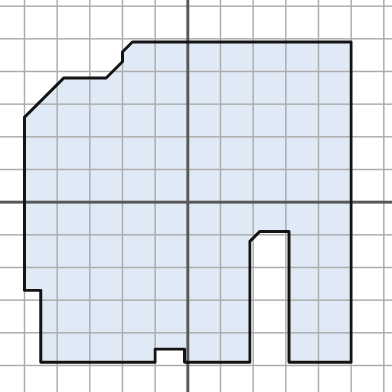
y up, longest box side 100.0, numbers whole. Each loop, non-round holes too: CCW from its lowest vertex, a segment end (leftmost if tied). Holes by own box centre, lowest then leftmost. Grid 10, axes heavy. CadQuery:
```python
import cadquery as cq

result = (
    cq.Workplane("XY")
    .moveTo(-45.0, -49.0)
    .lineTo(-10.0, -49.0)
    .lineTo(-10.0, -45.0)
    .lineTo(-1.0, -45.0)
    .lineTo(-1.0, -49.0)
    .lineTo(19.0, -49.0)
    .lineTo(19.0, -12.0)
    .lineTo(22.0, -9.0)
    .lineTo(31.0, -9.0)
    .lineTo(31.0, -49.0)
    .lineTo(50.0, -49.0)
    .lineTo(50.0, 49.0)
    .lineTo(-17.0, 49.0)
    .lineTo(-20.0, 46.0)
    .lineTo(-20.0, 43.0)
    .lineTo(-25.0, 38.0)
    .lineTo(-38.0, 38.0)
    .lineTo(-50.0, 26.0)
    .lineTo(-50.0, -27.0)
    .lineTo(-45.0, -27.0)
    .close()
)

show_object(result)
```